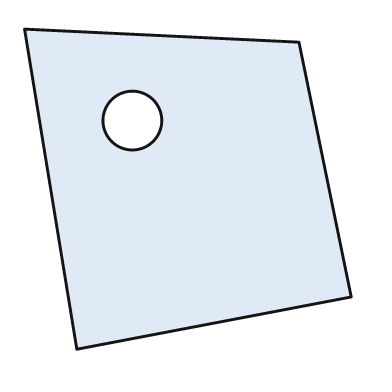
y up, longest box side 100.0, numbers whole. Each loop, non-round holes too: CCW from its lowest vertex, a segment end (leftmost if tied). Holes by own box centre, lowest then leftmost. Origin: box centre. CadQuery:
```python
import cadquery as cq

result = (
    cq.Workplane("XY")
    .moveTo(-34.0, -49.0)
    .lineTo(50.0, -33.0)
    .lineTo(34.0, 45.0)
    .lineTo(-50.0, 49.0)
    .close()
    .moveTo(-17.0, 21.0)
    .circle(9.0)
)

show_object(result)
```